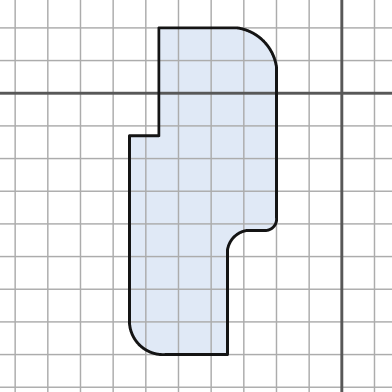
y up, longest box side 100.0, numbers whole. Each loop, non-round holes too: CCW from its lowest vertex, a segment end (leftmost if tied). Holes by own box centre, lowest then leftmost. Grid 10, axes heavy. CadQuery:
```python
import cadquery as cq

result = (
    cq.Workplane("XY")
    .moveTo(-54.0, -80.0)
    .lineTo(-35.0, -80.0)
    .lineTo(-35.0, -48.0)
    .threePointArc((-33.0, -44.0), (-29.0, -42.0))
    .lineTo(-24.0, -42.0)
    .threePointArc((-21.0, -41.0), (-20.0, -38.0))
    .lineTo(-20.0, 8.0)
    .threePointArc((-24.0, 16.0), (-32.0, 20.0))
    .lineTo(-56.0, 20.0)
    .lineTo(-56.0, -13.0)
    .lineTo(-65.0, -13.0)
    .lineTo(-65.0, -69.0)
    .threePointArc((-62.0, -77.0), (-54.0, -80.0))
    .close()
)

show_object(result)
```